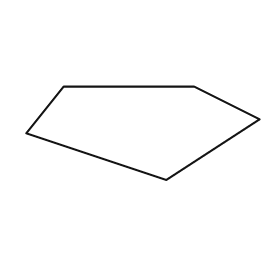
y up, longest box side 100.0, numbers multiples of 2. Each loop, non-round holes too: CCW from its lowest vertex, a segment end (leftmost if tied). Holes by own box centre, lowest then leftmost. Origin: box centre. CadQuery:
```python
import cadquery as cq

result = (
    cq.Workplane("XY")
    .moveTo(10.0, -20.0)
    .lineTo(50.0, 6.0)
    .lineTo(22.0, 20.0)
    .lineTo(-34.0, 20.0)
    .lineTo(-50.0, 0.0)
    .close()
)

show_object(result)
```